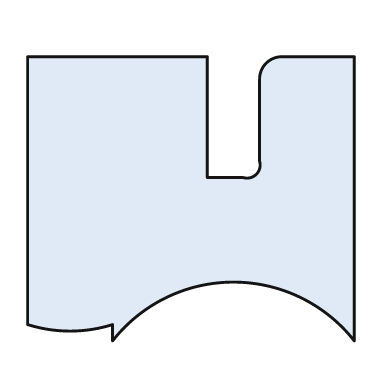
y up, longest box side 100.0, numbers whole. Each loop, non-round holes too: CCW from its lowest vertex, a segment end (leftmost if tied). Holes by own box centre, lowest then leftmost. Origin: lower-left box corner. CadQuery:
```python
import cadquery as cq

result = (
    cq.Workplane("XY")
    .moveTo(26.0, 0.0)
    .threePointArc((63.0, 18.0), (100.0, 0.0))
    .lineTo(100.0, 87.0)
    .lineTo(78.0, 87.0)
    .threePointArc((73.0, 85.0), (71.0, 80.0))
    .lineTo(71.0, 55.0)
    .threePointArc((70.0, 51.0), (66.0, 50.0))
    .lineTo(55.0, 50.0)
    .lineTo(55.0, 87.0)
    .lineTo(0.0, 87.0)
    .lineTo(0.0, 5.0)
    .threePointArc((13.0, 3.0), (26.0, 5.0))
    .close()
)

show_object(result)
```